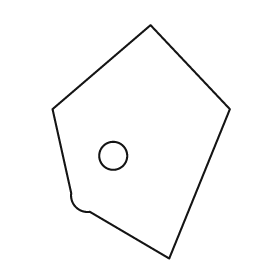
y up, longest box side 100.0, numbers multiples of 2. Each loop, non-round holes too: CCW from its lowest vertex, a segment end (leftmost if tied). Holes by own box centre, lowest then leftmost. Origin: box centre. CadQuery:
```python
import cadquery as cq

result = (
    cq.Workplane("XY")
    .moveTo(12.0, -50.0)
    .lineTo(38.0, 14.0)
    .lineTo(4.0, 50.0)
    .lineTo(-38.0, 14.0)
    .lineTo(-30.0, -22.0)
    .threePointArc((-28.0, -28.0), (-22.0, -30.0))
    .close()
    .moveTo(-12.0, -6.0)
    .circle(6.0)
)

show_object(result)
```